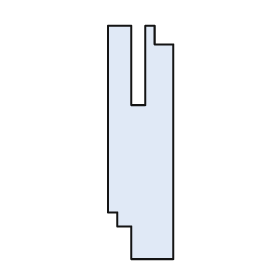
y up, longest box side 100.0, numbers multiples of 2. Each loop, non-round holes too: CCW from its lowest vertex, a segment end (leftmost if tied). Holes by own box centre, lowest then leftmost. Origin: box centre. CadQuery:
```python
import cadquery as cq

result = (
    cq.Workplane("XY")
    .moveTo(-4.0, -50.0)
    .lineTo(14.0, -50.0)
    .lineTo(14.0, 42.0)
    .lineTo(6.0, 42.0)
    .lineTo(6.0, 50.0)
    .lineTo(2.0, 50.0)
    .lineTo(2.0, 16.0)
    .lineTo(-4.0, 16.0)
    .lineTo(-4.0, 50.0)
    .lineTo(-14.0, 50.0)
    .lineTo(-14.0, -30.0)
    .lineTo(-10.0, -30.0)
    .lineTo(-10.0, -36.0)
    .lineTo(-4.0, -36.0)
    .close()
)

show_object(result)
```